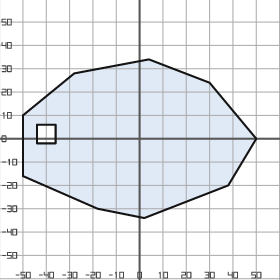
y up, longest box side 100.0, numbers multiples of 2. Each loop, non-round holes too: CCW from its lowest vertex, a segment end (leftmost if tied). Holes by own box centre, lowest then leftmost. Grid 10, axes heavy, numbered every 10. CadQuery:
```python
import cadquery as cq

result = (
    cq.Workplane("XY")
    .moveTo(2.0, -34.0)
    .lineTo(38.0, -20.0)
    .lineTo(50.0, 0.0)
    .lineTo(30.0, 24.0)
    .lineTo(4.0, 34.0)
    .lineTo(-28.0, 28.0)
    .lineTo(-50.0, 10.0)
    .lineTo(-50.0, -16.0)
    .lineTo(-18.0, -30.0)
    .close()
    .moveTo(-44.0, -2.0)
    .lineTo(-36.0, -2.0)
    .lineTo(-36.0, 6.0)
    .lineTo(-44.0, 6.0)
    .close()
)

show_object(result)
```